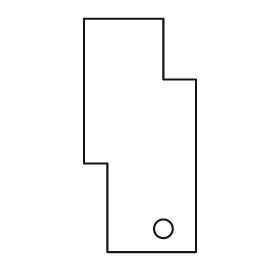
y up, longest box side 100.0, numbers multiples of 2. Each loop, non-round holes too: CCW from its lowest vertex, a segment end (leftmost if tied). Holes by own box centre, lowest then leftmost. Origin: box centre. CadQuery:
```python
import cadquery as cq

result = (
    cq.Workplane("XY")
    .moveTo(-14.0, -50.0)
    .lineTo(24.0, -50.0)
    .lineTo(24.0, 24.0)
    .lineTo(10.0, 24.0)
    .lineTo(10.0, 50.0)
    .lineTo(-24.0, 50.0)
    .lineTo(-24.0, -12.0)
    .lineTo(-14.0, -12.0)
    .close()
    .moveTo(10.0, -40.0)
    .circle(4.0)
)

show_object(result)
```